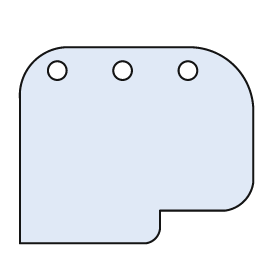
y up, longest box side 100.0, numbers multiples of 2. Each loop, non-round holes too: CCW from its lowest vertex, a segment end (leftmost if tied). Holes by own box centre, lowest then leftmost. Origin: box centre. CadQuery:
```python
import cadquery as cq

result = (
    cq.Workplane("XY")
    .moveTo(-50.0, -42.0)
    .lineTo(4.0, -42.0)
    .threePointArc((8.0, -40.0), (10.0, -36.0))
    .lineTo(10.0, -28.0)
    .lineTo(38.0, -28.0)
    .threePointArc((46.0, -24.0), (50.0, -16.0))
    .lineTo(50.0, 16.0)
    .threePointArc((42.0, 34.0), (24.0, 42.0))
    .lineTo(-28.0, 42.0)
    .threePointArc((-44.0, 36.0), (-50.0, 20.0))
    .close()
    .moveTo(-34.0, 32.0)
    .circle(4.0)
    .moveTo(-6.0, 32.0)
    .circle(4.0)
    .moveTo(22.0, 32.0)
    .circle(4.0)
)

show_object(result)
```